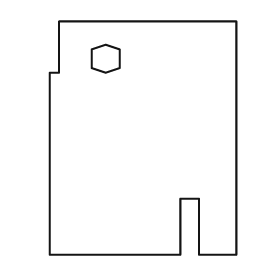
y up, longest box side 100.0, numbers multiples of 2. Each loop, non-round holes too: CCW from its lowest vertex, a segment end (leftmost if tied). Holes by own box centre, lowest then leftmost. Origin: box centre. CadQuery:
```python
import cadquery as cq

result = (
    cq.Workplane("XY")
    .moveTo(-40.0, -50.0)
    .lineTo(16.0, -50.0)
    .lineTo(16.0, -26.0)
    .lineTo(24.0, -26.0)
    .lineTo(24.0, -50.0)
    .lineTo(40.0, -50.0)
    .lineTo(40.0, 50.0)
    .lineTo(-36.0, 50.0)
    .lineTo(-36.0, 28.0)
    .lineTo(-40.0, 28.0)
    .close()
    .moveTo(-16.0, 28.0)
    .lineTo(-10.0, 30.0)
    .lineTo(-10.0, 38.0)
    .lineTo(-16.0, 40.0)
    .lineTo(-22.0, 38.0)
    .lineTo(-22.0, 30.0)
    .close()
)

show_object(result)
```